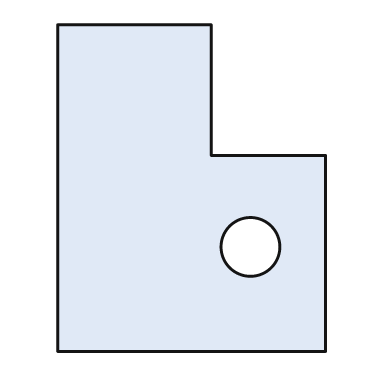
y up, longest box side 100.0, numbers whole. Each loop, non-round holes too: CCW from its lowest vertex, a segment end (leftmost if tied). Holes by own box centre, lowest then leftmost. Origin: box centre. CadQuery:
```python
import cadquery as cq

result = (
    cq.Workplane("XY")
    .moveTo(-41.0, -50.0)
    .lineTo(41.0, -50.0)
    .lineTo(41.0, 10.0)
    .lineTo(6.0, 10.0)
    .lineTo(6.0, 50.0)
    .lineTo(-41.0, 50.0)
    .close()
    .moveTo(18.0, -18.0)
    .circle(9.0)
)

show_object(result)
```